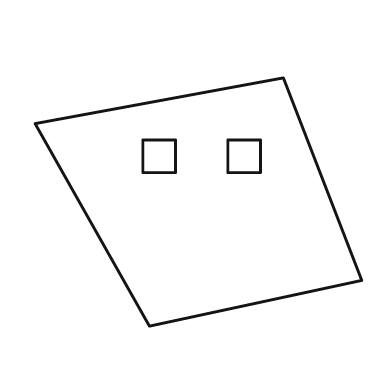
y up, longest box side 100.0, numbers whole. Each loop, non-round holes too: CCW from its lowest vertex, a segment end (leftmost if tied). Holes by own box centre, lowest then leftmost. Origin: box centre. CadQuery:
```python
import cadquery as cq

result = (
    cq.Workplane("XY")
    .moveTo(-15.0, -38.0)
    .lineTo(50.0, -24.0)
    .lineTo(26.0, 38.0)
    .lineTo(-50.0, 24.0)
    .close()
    .moveTo(-17.0, 9.0)
    .lineTo(-7.0, 9.0)
    .lineTo(-7.0, 19.0)
    .lineTo(-17.0, 19.0)
    .close()
    .moveTo(9.0, 9.0)
    .lineTo(19.0, 9.0)
    .lineTo(19.0, 19.0)
    .lineTo(9.0, 19.0)
    .close()
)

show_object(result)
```